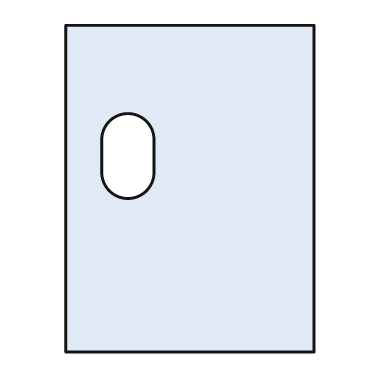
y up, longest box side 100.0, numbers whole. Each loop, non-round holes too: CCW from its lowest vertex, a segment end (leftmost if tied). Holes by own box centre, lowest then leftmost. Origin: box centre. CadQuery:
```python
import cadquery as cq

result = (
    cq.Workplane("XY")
    .moveTo(-38.0, -50.0)
    .lineTo(38.0, -50.0)
    .lineTo(38.0, 50.0)
    .lineTo(-38.0, 50.0)
    .close()
    .moveTo(-27.0, 5.0)
    .threePointArc((-19.0, -3.0), (-11.0, 5.0))
    .lineTo(-11.0, 15.0)
    .threePointArc((-19.0, 23.0), (-27.0, 15.0))
    .close()
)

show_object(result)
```